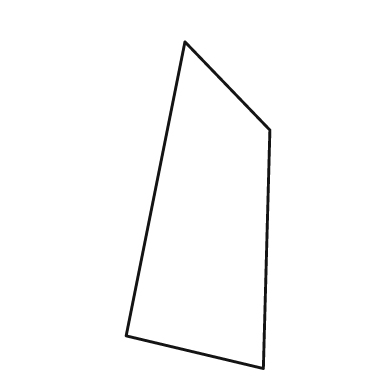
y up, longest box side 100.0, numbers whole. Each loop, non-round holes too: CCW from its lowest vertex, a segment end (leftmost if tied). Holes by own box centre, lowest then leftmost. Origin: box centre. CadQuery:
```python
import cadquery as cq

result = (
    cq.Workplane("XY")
    .moveTo(20.0, -50.0)
    .lineTo(22.0, 23.0)
    .lineTo(-4.0, 50.0)
    .lineTo(-22.0, -40.0)
    .close()
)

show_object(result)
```